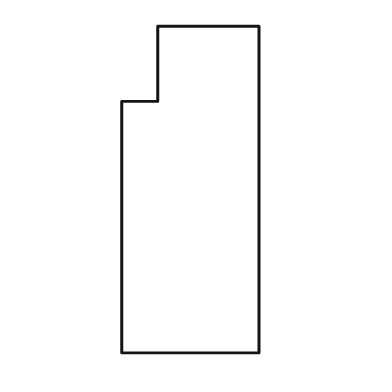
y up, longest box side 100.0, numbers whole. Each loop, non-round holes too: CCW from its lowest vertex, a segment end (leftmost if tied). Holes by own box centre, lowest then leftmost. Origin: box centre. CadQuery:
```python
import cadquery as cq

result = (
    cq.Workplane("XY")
    .moveTo(-21.0, -50.0)
    .lineTo(21.0, -50.0)
    .lineTo(21.0, 50.0)
    .lineTo(-10.0, 50.0)
    .lineTo(-10.0, 27.0)
    .lineTo(-21.0, 27.0)
    .close()
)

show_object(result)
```